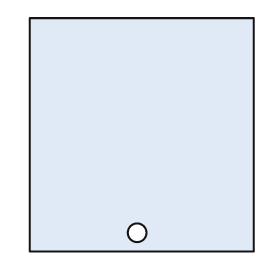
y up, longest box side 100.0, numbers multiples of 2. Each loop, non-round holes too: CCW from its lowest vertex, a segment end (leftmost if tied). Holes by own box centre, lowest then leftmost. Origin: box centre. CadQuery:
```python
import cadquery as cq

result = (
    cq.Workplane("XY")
    .moveTo(-48.0, -50.0)
    .lineTo(48.0, -50.0)
    .lineTo(48.0, 50.0)
    .lineTo(-48.0, 50.0)
    .close()
    .moveTo(-2.0, -42.0)
    .circle(4.0)
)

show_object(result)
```